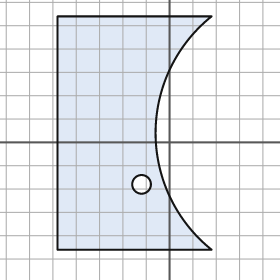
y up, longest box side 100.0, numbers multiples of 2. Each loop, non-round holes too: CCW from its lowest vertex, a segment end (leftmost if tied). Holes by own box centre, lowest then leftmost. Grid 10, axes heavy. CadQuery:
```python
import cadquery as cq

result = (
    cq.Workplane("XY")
    .moveTo(-48.0, -46.0)
    .lineTo(18.0, -46.0)
    .threePointArc((-6.0, 4.0), (18.0, 54.0))
    .lineTo(-48.0, 54.0)
    .close()
    .moveTo(-12.0, -18.0)
    .circle(4.0)
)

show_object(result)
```